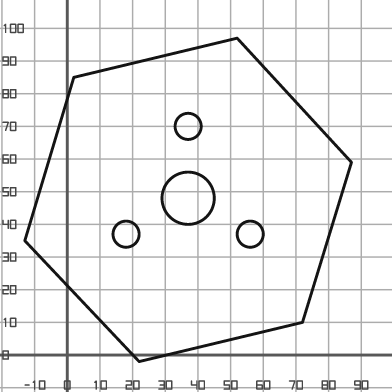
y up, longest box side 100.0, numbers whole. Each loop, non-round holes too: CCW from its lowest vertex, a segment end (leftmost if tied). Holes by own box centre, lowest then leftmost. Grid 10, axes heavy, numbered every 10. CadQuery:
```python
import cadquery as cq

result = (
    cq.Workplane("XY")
    .moveTo(22.0, -2.0)
    .lineTo(72.0, 10.0)
    .lineTo(87.0, 59.0)
    .lineTo(52.0, 97.0)
    .lineTo(2.0, 85.0)
    .lineTo(-13.0, 35.0)
    .close()
    .moveTo(18.0, 37.0)
    .circle(4.0)
    .moveTo(56.0, 37.0)
    .circle(4.0)
    .moveTo(37.0, 48.0)
    .circle(8.0)
    .moveTo(37.0, 70.0)
    .circle(4.0)
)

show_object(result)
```